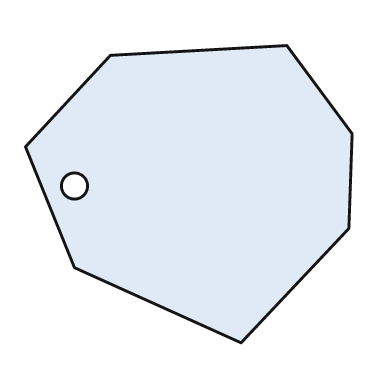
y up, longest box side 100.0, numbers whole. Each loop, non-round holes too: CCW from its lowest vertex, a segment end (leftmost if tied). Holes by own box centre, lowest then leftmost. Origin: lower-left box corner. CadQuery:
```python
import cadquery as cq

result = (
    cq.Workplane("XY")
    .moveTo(66.0, 0.0)
    .lineTo(99.0, 35.0)
    .lineTo(100.0, 64.0)
    .lineTo(80.0, 91.0)
    .lineTo(26.0, 88.0)
    .lineTo(0.0, 60.0)
    .lineTo(15.0, 23.0)
    .close()
    .moveTo(15.0, 48.0)
    .circle(4.0)
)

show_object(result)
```